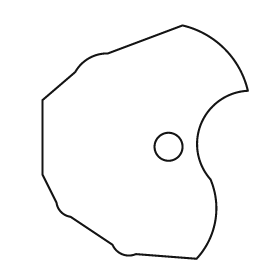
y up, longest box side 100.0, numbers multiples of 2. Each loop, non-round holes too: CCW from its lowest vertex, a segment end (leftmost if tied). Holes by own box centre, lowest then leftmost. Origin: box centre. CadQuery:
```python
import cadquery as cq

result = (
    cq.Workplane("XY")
    .moveTo(22.0, -50.0)
    .threePointArc((30.0, -34.0), (28.0, -16.0))
    .threePointArc((24.0, 8.0), (44.0, 22.0))
    .threePointArc((34.0, 40.0), (16.0, 50.0))
    .lineTo(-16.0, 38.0)
    .threePointArc((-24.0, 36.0), (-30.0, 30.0))
    .lineTo(-44.0, 18.0)
    .lineTo(-44.0, -14.0)
    .lineTo(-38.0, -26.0)
    .threePointArc((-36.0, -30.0), (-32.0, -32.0))
    .lineTo(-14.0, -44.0)
    .threePointArc((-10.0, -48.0), (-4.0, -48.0))
    .close()
    .moveTo(10.0, -2.0)
    .circle(6.0)
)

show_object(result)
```